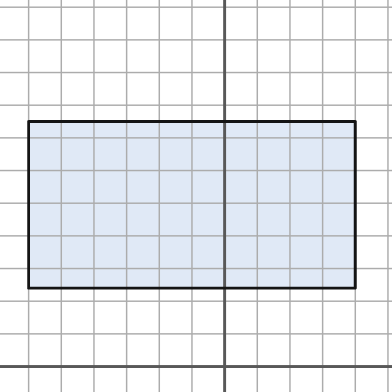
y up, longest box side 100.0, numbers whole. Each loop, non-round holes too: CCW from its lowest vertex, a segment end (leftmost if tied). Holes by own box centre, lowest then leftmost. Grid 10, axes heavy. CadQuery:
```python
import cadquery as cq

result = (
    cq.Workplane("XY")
    .moveTo(-60.0, 24.0)
    .lineTo(40.0, 24.0)
    .lineTo(40.0, 75.0)
    .lineTo(-60.0, 75.0)
    .close()
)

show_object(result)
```